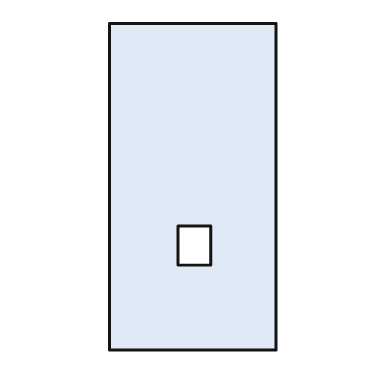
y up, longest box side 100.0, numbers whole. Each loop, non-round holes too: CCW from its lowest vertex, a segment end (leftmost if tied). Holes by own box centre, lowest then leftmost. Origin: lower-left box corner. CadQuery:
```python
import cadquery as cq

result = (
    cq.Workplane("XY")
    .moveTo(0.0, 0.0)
    .lineTo(51.0, 0.0)
    .lineTo(51.0, 100.0)
    .lineTo(0.0, 100.0)
    .close()
    .moveTo(21.0, 26.0)
    .lineTo(31.0, 26.0)
    .lineTo(31.0, 38.0)
    .lineTo(21.0, 38.0)
    .close()
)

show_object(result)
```